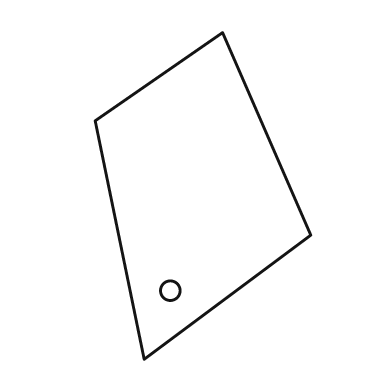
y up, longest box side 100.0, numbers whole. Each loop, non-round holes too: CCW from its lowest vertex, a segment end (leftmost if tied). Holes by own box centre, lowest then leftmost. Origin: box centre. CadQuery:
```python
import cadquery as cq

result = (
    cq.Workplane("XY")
    .moveTo(-18.0, -50.0)
    .lineTo(33.0, -12.0)
    .lineTo(6.0, 50.0)
    .lineTo(-33.0, 23.0)
    .close()
    .moveTo(-10.0, -29.0)
    .circle(3.0)
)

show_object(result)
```